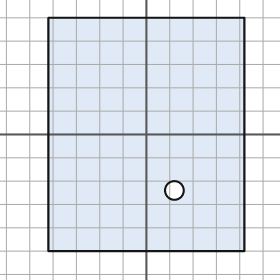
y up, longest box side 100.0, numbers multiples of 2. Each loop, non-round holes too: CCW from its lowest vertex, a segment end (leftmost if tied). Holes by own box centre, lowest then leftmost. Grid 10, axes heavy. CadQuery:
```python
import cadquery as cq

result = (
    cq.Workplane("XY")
    .moveTo(-42.0, -50.0)
    .lineTo(42.0, -50.0)
    .lineTo(42.0, 50.0)
    .lineTo(-42.0, 50.0)
    .close()
    .moveTo(12.0, -24.0)
    .circle(4.0)
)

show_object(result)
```